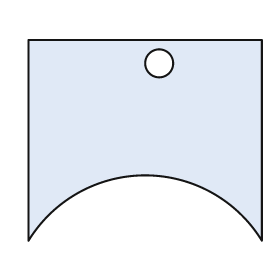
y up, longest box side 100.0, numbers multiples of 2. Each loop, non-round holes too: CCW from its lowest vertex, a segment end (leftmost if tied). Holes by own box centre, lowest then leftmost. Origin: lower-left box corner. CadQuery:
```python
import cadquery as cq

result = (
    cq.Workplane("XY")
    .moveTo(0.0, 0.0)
    .threePointArc((50.0, 28.0), (100.0, 0.0))
    .lineTo(100.0, 86.0)
    .lineTo(0.0, 86.0)
    .close()
    .moveTo(56.0, 76.0)
    .circle(6.0)
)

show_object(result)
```